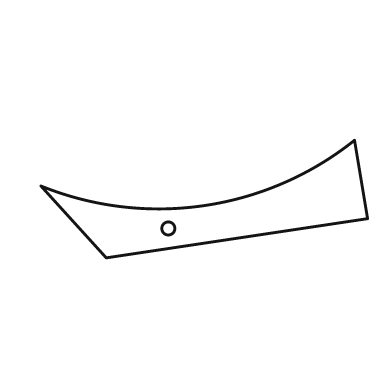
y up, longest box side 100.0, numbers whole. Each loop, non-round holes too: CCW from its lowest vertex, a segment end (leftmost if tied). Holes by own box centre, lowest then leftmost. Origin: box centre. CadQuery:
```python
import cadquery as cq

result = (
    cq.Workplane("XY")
    .moveTo(-30.0, -18.0)
    .lineTo(50.0, -6.0)
    .lineTo(46.0, 18.0)
    .threePointArc((0.0, -2.0), (-50.0, 4.0))
    .close()
    .moveTo(-11.0, -9.0)
    .circle(2.0)
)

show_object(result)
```